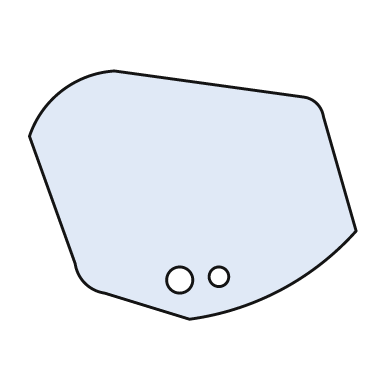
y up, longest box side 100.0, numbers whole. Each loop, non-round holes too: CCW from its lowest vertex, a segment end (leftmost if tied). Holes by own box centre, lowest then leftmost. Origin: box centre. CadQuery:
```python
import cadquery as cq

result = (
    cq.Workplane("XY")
    .moveTo(-1.0, -38.0)
    .threePointArc((27.0, -29.0), (50.0, -11.0))
    .lineTo(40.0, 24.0)
    .threePointArc((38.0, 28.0), (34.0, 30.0))
    .lineTo(-24.0, 38.0)
    .threePointArc((-40.0, 32.0), (-50.0, 18.0))
    .lineTo(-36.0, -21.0)
    .threePointArc((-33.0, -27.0), (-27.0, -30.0))
    .close()
    .moveTo(-4.0, -26.0)
    .circle(4.0)
    .moveTo(8.0, -25.0)
    .circle(3.0)
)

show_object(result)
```